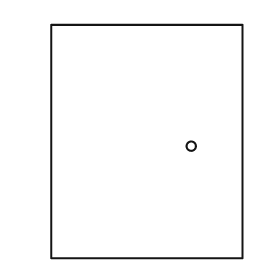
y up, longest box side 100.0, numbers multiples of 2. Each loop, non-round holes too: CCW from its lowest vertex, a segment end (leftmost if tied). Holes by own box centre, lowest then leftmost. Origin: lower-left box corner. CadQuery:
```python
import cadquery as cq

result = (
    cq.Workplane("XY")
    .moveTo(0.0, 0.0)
    .lineTo(82.0, 0.0)
    .lineTo(82.0, 100.0)
    .lineTo(0.0, 100.0)
    .close()
    .moveTo(60.0, 48.0)
    .circle(2.0)
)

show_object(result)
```